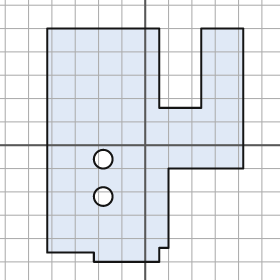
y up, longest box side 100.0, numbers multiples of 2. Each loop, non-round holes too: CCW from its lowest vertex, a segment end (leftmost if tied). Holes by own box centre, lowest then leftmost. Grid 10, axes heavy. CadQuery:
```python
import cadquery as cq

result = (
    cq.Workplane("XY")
    .moveTo(-22.0, -50.0)
    .lineTo(6.0, -50.0)
    .lineTo(6.0, -44.0)
    .lineTo(10.0, -44.0)
    .lineTo(10.0, -10.0)
    .lineTo(42.0, -10.0)
    .lineTo(42.0, 50.0)
    .lineTo(24.0, 50.0)
    .lineTo(24.0, 16.0)
    .lineTo(6.0, 16.0)
    .lineTo(6.0, 50.0)
    .lineTo(-42.0, 50.0)
    .lineTo(-42.0, -46.0)
    .lineTo(-22.0, -46.0)
    .close()
    .moveTo(-18.0, -22.0)
    .circle(4.0)
    .moveTo(-18.0, -6.0)
    .circle(4.0)
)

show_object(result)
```